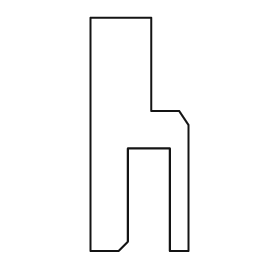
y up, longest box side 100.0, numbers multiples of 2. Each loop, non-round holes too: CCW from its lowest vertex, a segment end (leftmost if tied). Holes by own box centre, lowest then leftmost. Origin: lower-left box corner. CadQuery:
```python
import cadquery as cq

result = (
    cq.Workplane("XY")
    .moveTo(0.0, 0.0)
    .lineTo(12.0, 0.0)
    .lineTo(16.0, 4.0)
    .lineTo(16.0, 44.0)
    .lineTo(34.0, 44.0)
    .lineTo(34.0, 0.0)
    .lineTo(42.0, 0.0)
    .lineTo(42.0, 54.0)
    .lineTo(38.0, 60.0)
    .lineTo(26.0, 60.0)
    .lineTo(26.0, 100.0)
    .lineTo(0.0, 100.0)
    .close()
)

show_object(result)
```